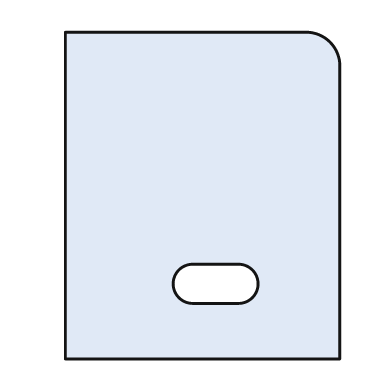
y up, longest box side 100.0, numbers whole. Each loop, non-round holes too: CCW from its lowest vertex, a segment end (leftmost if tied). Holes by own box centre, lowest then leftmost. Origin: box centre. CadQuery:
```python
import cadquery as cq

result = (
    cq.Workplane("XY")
    .moveTo(-42.0, -50.0)
    .lineTo(42.0, -50.0)
    .lineTo(42.0, 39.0)
    .threePointArc((39.0, 47.0), (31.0, 50.0))
    .lineTo(-42.0, 50.0)
    .close()
    .moveTo(-3.0, -33.0)
    .lineTo(11.0, -33.0)
    .threePointArc((17.0, -27.0), (11.0, -21.0))
    .lineTo(-3.0, -21.0)
    .threePointArc((-9.0, -27.0), (-3.0, -33.0))
    .close()
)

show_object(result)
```